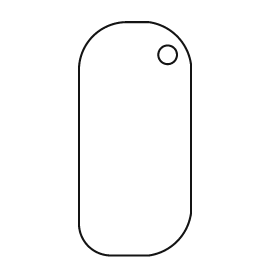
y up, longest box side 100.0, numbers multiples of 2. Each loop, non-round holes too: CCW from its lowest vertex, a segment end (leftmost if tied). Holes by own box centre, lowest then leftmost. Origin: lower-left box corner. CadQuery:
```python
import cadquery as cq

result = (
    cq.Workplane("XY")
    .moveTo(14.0, 0.0)
    .lineTo(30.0, 0.0)
    .threePointArc((42.0, 6.0), (48.0, 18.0))
    .lineTo(48.0, 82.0)
    .threePointArc((42.0, 94.0), (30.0, 100.0))
    .lineTo(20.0, 100.0)
    .threePointArc((6.0, 94.0), (0.0, 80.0))
    .lineTo(0.0, 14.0)
    .threePointArc((4.0, 4.0), (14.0, 0.0))
    .close()
    .moveTo(38.0, 86.0)
    .circle(4.0)
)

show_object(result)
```